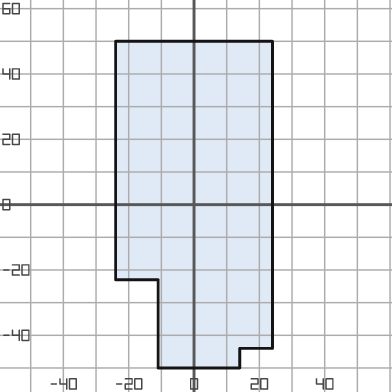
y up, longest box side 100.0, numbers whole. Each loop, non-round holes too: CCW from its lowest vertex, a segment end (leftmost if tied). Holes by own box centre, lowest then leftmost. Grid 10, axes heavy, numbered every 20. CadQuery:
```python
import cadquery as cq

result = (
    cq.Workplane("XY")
    .moveTo(-11.0, -50.0)
    .lineTo(14.0, -50.0)
    .lineTo(14.0, -44.0)
    .lineTo(24.0, -44.0)
    .lineTo(24.0, 50.0)
    .lineTo(-24.0, 50.0)
    .lineTo(-24.0, -23.0)
    .lineTo(-11.0, -23.0)
    .close()
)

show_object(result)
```